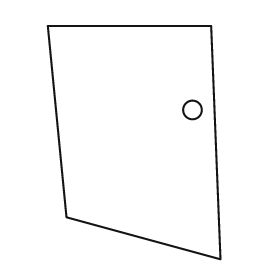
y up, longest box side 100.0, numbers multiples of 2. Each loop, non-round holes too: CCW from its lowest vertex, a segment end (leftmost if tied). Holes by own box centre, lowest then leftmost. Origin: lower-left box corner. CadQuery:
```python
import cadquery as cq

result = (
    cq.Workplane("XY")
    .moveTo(74.0, 0.0)
    .lineTo(70.0, 100.0)
    .lineTo(0.0, 100.0)
    .lineTo(8.0, 18.0)
    .close()
    .moveTo(62.0, 64.0)
    .circle(4.0)
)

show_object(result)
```